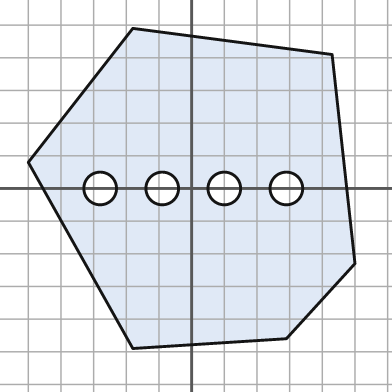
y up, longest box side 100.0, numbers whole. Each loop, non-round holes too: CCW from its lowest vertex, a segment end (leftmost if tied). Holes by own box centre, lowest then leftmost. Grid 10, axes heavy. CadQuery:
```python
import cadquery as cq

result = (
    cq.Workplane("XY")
    .moveTo(-18.0, -49.0)
    .lineTo(29.0, -46.0)
    .lineTo(50.0, -23.0)
    .lineTo(43.0, 41.0)
    .lineTo(-18.0, 49.0)
    .lineTo(-50.0, 8.0)
    .close()
    .moveTo(-28.0, 0.0)
    .circle(5.0)
    .moveTo(-9.0, 0.0)
    .circle(5.0)
    .moveTo(10.0, 0.0)
    .circle(5.0)
    .moveTo(29.0, 0.0)
    .circle(5.0)
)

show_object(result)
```